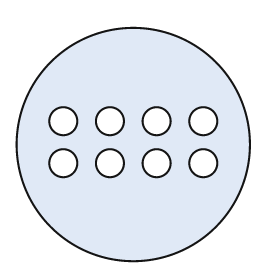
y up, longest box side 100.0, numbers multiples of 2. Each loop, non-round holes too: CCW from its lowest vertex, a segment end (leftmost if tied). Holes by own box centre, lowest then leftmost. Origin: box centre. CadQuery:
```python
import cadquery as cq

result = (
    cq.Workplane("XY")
    .moveTo(0.0, 0.0)
    .circle(50.0)
    .moveTo(-30.0, -8.0)
    .circle(6.0)
    .moveTo(-10.0, -8.0)
    .circle(6.0)
    .moveTo(10.0, -8.0)
    .circle(6.0)
    .moveTo(30.0, -8.0)
    .circle(6.0)
    .moveTo(-30.0, 10.0)
    .circle(6.0)
    .moveTo(-10.0, 10.0)
    .circle(6.0)
    .moveTo(10.0, 10.0)
    .circle(6.0)
    .moveTo(30.0, 10.0)
    .circle(6.0)
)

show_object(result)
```